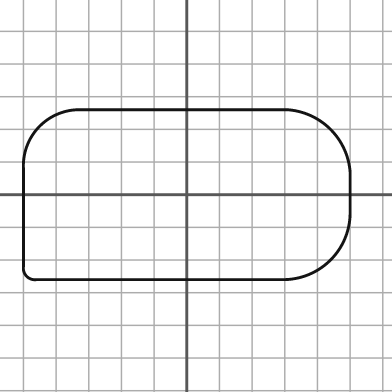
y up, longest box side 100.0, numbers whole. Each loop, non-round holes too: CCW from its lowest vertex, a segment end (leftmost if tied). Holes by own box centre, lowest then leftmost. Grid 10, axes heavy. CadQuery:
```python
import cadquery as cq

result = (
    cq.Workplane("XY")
    .moveTo(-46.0, -26.0)
    .lineTo(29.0, -26.0)
    .threePointArc((44.0, -20.0), (50.0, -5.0))
    .lineTo(50.0, 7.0)
    .threePointArc((44.0, 20.0), (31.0, 26.0))
    .lineTo(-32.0, 26.0)
    .threePointArc((-45.0, 21.0), (-50.0, 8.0))
    .lineTo(-50.0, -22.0)
    .threePointArc((-49.0, -25.0), (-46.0, -26.0))
    .close()
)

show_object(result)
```